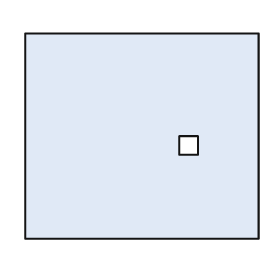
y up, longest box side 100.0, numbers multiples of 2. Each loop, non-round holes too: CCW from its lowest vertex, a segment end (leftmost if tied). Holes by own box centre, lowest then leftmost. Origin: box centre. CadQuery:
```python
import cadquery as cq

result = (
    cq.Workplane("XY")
    .moveTo(-50.0, -44.0)
    .lineTo(50.0, -44.0)
    .lineTo(50.0, 44.0)
    .lineTo(-50.0, 44.0)
    .close()
    .moveTo(16.0, -8.0)
    .lineTo(24.0, -8.0)
    .lineTo(24.0, 0.0)
    .lineTo(16.0, 0.0)
    .close()
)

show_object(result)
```